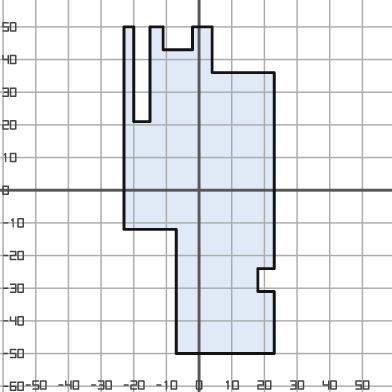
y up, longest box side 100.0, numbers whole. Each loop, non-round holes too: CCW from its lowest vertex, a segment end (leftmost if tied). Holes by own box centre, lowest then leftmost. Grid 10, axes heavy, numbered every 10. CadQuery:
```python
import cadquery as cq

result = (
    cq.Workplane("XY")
    .moveTo(-7.0, -50.0)
    .lineTo(23.0, -50.0)
    .lineTo(23.0, -31.0)
    .lineTo(18.0, -31.0)
    .lineTo(18.0, -24.0)
    .lineTo(23.0, -24.0)
    .lineTo(23.0, 36.0)
    .lineTo(4.0, 36.0)
    .lineTo(4.0, 50.0)
    .lineTo(-2.0, 50.0)
    .lineTo(-2.0, 43.0)
    .lineTo(-11.0, 43.0)
    .lineTo(-11.0, 50.0)
    .lineTo(-15.0, 50.0)
    .lineTo(-15.0, 21.0)
    .lineTo(-20.0, 21.0)
    .lineTo(-20.0, 50.0)
    .lineTo(-23.0, 50.0)
    .lineTo(-23.0, -12.0)
    .lineTo(-7.0, -12.0)
    .close()
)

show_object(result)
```